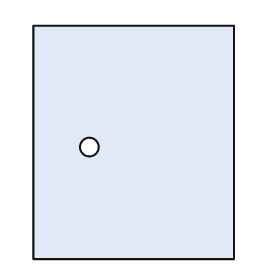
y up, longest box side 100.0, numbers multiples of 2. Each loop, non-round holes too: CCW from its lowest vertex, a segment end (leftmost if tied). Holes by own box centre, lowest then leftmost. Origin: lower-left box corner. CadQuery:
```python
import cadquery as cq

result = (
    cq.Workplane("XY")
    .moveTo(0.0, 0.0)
    .lineTo(86.0, 0.0)
    .lineTo(86.0, 100.0)
    .lineTo(0.0, 100.0)
    .close()
    .moveTo(24.0, 48.0)
    .circle(4.0)
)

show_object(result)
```